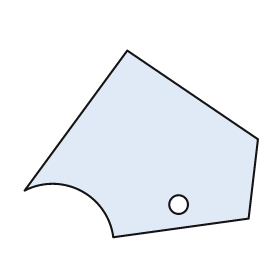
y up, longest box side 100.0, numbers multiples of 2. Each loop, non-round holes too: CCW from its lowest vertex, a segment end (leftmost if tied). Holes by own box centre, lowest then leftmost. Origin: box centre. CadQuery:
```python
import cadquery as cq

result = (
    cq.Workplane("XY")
    .moveTo(-12.0, -40.0)
    .lineTo(46.0, -32.0)
    .lineTo(50.0, 2.0)
    .lineTo(-6.0, 40.0)
    .lineTo(-50.0, -20.0)
    .threePointArc((-26.0, -20.0), (-12.0, -40.0))
    .close()
    .moveTo(16.0, -26.0)
    .circle(4.0)
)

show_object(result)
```